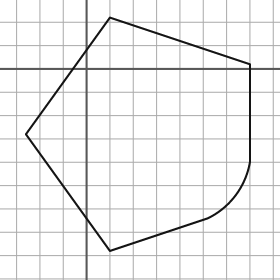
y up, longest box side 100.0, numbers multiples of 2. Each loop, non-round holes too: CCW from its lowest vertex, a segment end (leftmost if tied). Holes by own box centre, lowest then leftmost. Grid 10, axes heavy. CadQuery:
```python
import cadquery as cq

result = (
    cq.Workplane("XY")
    .moveTo(10.0, -78.0)
    .lineTo(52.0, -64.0)
    .threePointArc((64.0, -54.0), (70.0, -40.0))
    .lineTo(70.0, 2.0)
    .lineTo(10.0, 22.0)
    .lineTo(-26.0, -28.0)
    .close()
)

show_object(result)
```